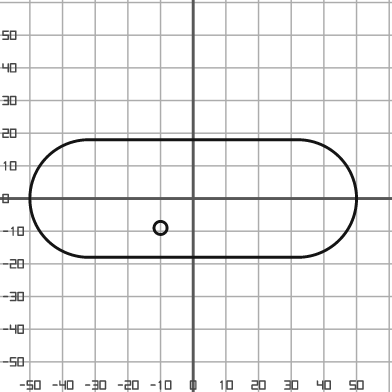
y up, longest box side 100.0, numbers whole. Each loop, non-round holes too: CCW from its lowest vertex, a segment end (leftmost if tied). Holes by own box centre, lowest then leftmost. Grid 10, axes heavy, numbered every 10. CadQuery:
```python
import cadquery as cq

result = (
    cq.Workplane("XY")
    .moveTo(-32.0, -18.0)
    .lineTo(32.0, -18.0)
    .threePointArc((50.0, 0.0), (32.0, 18.0))
    .lineTo(-32.0, 18.0)
    .threePointArc((-50.0, 0.0), (-32.0, -18.0))
    .close()
    .moveTo(-10.0, -9.0)
    .circle(2.0)
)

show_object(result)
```